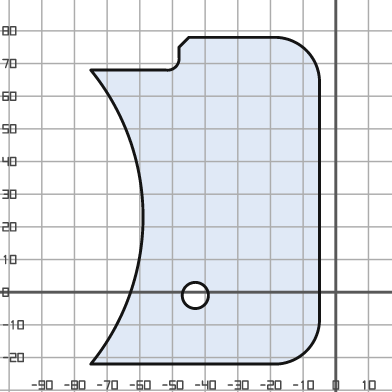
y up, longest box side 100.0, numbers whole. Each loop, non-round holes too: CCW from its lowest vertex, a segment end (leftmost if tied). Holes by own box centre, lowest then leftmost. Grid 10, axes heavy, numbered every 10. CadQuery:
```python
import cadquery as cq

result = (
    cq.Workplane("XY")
    .moveTo(-75.0, -22.0)
    .lineTo(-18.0, -22.0)
    .threePointArc((-9.0, -18.0), (-5.0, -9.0))
    .lineTo(-5.0, 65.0)
    .threePointArc((-9.0, 74.0), (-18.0, 78.0))
    .lineTo(-45.0, 78.0)
    .lineTo(-48.0, 75.0)
    .lineTo(-48.0, 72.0)
    .threePointArc((-49.0, 69.0), (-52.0, 68.0))
    .lineTo(-75.0, 68.0)
    .threePointArc((-59.0, 23.0), (-75.0, -22.0))
    .close()
    .moveTo(-43.0, -1.0)
    .circle(4.0)
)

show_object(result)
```